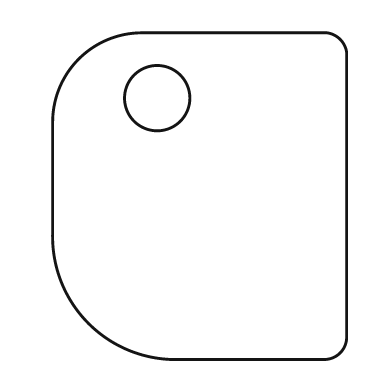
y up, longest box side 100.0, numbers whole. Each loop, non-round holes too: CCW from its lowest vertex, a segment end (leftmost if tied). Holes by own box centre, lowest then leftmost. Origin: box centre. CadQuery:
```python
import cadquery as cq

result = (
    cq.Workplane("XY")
    .moveTo(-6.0, -50.0)
    .lineTo(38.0, -50.0)
    .threePointArc((43.0, -48.0), (45.0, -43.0))
    .lineTo(45.0, 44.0)
    .threePointArc((43.0, 48.0), (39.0, 50.0))
    .lineTo(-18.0, 50.0)
    .threePointArc((-37.0, 42.0), (-45.0, 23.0))
    .lineTo(-45.0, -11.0)
    .threePointArc((-34.0, -39.0), (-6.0, -50.0))
    .close()
    .moveTo(-13.0, 30.0)
    .circle(10.0)
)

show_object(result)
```